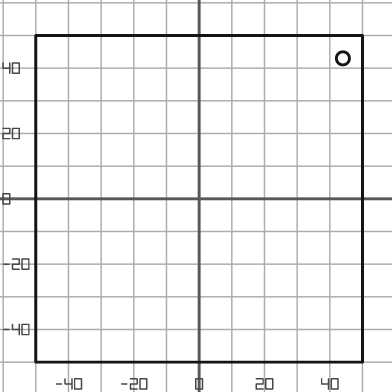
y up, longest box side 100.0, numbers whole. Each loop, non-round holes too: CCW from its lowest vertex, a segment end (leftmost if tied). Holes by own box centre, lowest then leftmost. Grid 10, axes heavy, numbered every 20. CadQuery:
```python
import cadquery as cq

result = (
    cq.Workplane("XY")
    .moveTo(-50.0, -50.0)
    .lineTo(50.0, -50.0)
    .lineTo(50.0, 50.0)
    .lineTo(-50.0, 50.0)
    .close()
    .moveTo(44.0, 43.0)
    .circle(2.0)
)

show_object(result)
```